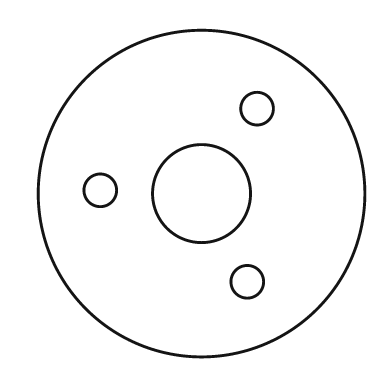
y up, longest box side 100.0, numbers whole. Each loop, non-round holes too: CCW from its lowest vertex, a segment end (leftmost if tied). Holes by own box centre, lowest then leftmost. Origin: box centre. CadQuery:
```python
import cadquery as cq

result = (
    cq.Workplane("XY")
    .moveTo(0.0, 0.0)
    .circle(50.0)
    .moveTo(14.0, -27.0)
    .circle(5.0)
    .moveTo(0.0, 0.0)
    .circle(15.0)
    .moveTo(-31.0, 1.0)
    .circle(5.0)
    .moveTo(17.0, 26.0)
    .circle(5.0)
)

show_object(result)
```